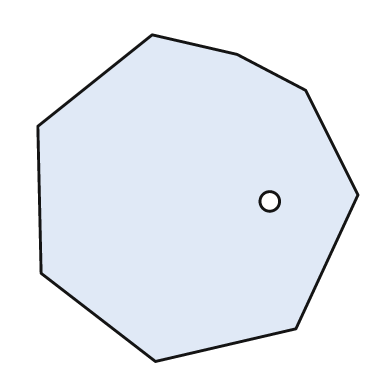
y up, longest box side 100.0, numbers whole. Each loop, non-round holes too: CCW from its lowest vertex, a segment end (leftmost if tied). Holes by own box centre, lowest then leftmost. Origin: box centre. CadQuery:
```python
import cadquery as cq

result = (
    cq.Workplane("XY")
    .moveTo(-13.0, -50.0)
    .lineTo(30.0, -40.0)
    .lineTo(49.0, 1.0)
    .lineTo(33.0, 33.0)
    .lineTo(12.0, 44.0)
    .lineTo(-14.0, 50.0)
    .lineTo(-49.0, 22.0)
    .lineTo(-48.0, -23.0)
    .close()
    .moveTo(22.0, -1.0)
    .circle(3.0)
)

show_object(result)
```